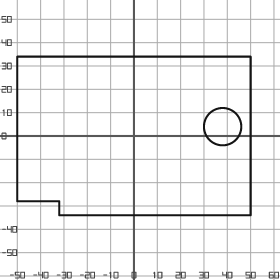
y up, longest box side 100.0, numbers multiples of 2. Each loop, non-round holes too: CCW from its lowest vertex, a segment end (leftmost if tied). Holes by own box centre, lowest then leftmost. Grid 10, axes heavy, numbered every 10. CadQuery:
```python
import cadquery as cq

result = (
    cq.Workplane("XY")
    .moveTo(-32.0, -34.0)
    .lineTo(50.0, -34.0)
    .lineTo(50.0, 34.0)
    .lineTo(-50.0, 34.0)
    .lineTo(-50.0, -28.0)
    .lineTo(-32.0, -28.0)
    .close()
    .moveTo(38.0, 4.0)
    .circle(8.0)
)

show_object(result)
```